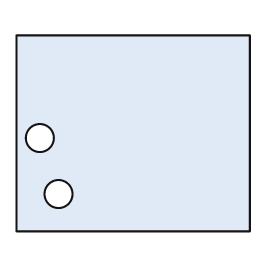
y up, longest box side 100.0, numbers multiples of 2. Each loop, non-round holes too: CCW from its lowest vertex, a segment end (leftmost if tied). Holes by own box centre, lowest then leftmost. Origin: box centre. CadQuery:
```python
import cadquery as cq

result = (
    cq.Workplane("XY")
    .moveTo(-50.0, -42.0)
    .lineTo(50.0, -42.0)
    .lineTo(50.0, 42.0)
    .lineTo(-50.0, 42.0)
    .close()
    .moveTo(-32.0, -26.0)
    .circle(6.0)
    .moveTo(-40.0, -2.0)
    .circle(6.0)
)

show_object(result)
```